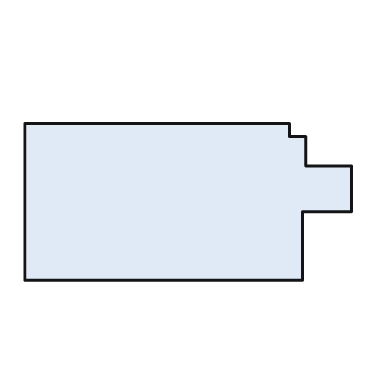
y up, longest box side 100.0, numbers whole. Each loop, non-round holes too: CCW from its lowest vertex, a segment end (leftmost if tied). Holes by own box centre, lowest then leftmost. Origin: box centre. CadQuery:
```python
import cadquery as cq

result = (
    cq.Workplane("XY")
    .moveTo(-50.0, -24.0)
    .lineTo(35.0, -24.0)
    .lineTo(35.0, -3.0)
    .lineTo(50.0, -3.0)
    .lineTo(50.0, 11.0)
    .lineTo(36.0, 11.0)
    .lineTo(36.0, 20.0)
    .lineTo(31.0, 20.0)
    .lineTo(31.0, 24.0)
    .lineTo(-50.0, 24.0)
    .close()
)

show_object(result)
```